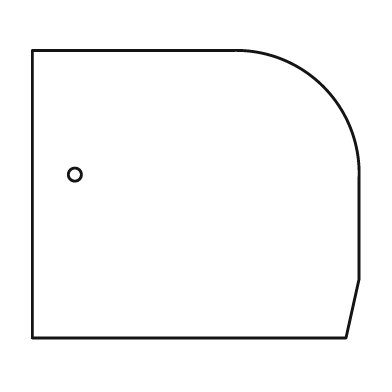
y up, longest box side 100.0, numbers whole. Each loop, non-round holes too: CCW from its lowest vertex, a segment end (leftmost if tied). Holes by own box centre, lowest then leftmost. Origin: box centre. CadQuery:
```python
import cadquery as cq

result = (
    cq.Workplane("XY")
    .moveTo(-50.0, -44.0)
    .lineTo(46.0, -44.0)
    .lineTo(50.0, -26.0)
    .lineTo(50.0, 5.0)
    .threePointArc((39.0, 33.0), (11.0, 44.0))
    .lineTo(-50.0, 44.0)
    .close()
    .moveTo(-37.0, 6.0)
    .circle(2.0)
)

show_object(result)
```